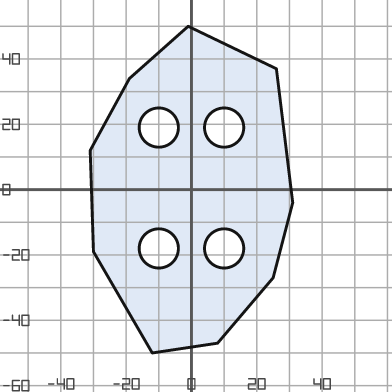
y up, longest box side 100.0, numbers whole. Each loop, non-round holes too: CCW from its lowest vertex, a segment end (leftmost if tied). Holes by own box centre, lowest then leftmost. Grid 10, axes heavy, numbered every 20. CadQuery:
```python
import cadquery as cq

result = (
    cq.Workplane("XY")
    .moveTo(-12.0, -50.0)
    .lineTo(8.0, -47.0)
    .lineTo(25.0, -27.0)
    .lineTo(31.0, -4.0)
    .lineTo(26.0, 37.0)
    .lineTo(-1.0, 50.0)
    .lineTo(-19.0, 34.0)
    .lineTo(-31.0, 12.0)
    .lineTo(-30.0, -19.0)
    .close()
    .moveTo(-10.0, -18.0)
    .circle(6.0)
    .moveTo(10.0, -18.0)
    .circle(6.0)
    .moveTo(-10.0, 19.0)
    .circle(6.0)
    .moveTo(10.0, 19.0)
    .circle(6.0)
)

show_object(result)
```